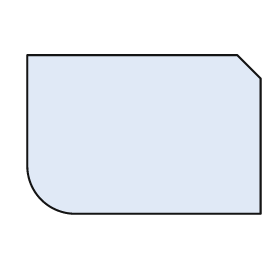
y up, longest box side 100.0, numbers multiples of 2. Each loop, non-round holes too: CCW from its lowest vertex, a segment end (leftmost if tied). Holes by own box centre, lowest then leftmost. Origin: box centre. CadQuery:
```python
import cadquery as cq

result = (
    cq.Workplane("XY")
    .moveTo(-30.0, -34.0)
    .lineTo(50.0, -34.0)
    .lineTo(50.0, 24.0)
    .lineTo(40.0, 34.0)
    .lineTo(-50.0, 34.0)
    .lineTo(-50.0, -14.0)
    .threePointArc((-44.0, -28.0), (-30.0, -34.0))
    .close()
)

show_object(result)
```